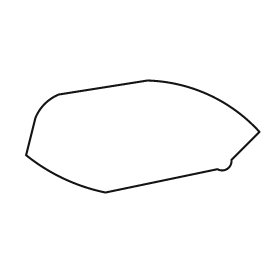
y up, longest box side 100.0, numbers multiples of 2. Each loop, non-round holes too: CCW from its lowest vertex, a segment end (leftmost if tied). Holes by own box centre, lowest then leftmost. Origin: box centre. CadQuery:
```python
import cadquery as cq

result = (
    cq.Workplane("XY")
    .moveTo(-16.0, -24.0)
    .lineTo(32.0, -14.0)
    .threePointArc((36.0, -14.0), (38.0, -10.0))
    .lineTo(50.0, 2.0)
    .threePointArc((28.0, 18.0), (2.0, 24.0))
    .lineTo(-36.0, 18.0)
    .threePointArc((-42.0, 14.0), (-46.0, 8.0))
    .lineTo(-50.0, -8.0)
    .threePointArc((-34.0, -18.0), (-16.0, -24.0))
    .close()
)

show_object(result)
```